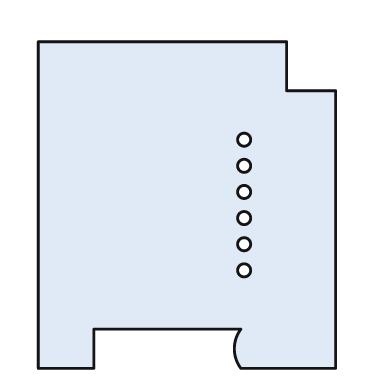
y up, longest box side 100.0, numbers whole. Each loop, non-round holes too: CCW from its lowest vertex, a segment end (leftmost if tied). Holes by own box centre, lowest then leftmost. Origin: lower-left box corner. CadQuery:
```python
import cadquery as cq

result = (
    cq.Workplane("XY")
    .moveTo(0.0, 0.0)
    .lineTo(17.0, 0.0)
    .lineTo(17.0, 12.0)
    .lineTo(62.0, 12.0)
    .threePointArc((60.0, 6.0), (62.0, 0.0))
    .lineTo(91.0, 0.0)
    .lineTo(91.0, 85.0)
    .lineTo(76.0, 85.0)
    .lineTo(76.0, 100.0)
    .lineTo(0.0, 100.0)
    .close()
    .moveTo(63.0, 30.0)
    .circle(2.0)
    .moveTo(63.0, 38.0)
    .circle(2.0)
    .moveTo(63.0, 46.0)
    .circle(2.0)
    .moveTo(63.0, 54.0)
    .circle(2.0)
    .moveTo(63.0, 62.0)
    .circle(2.0)
    .moveTo(63.0, 70.0)
    .circle(2.0)
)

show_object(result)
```